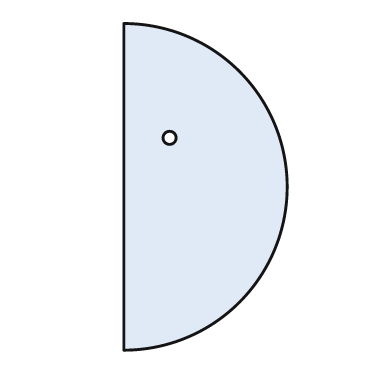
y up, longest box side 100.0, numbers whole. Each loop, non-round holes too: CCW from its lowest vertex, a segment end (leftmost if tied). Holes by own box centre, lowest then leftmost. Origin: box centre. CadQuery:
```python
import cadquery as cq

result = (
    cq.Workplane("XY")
    .moveTo(-25.0, -50.0)
    .threePointArc((25.0, 0.0), (-25.0, 50.0))
    .close()
    .moveTo(-11.0, 15.0)
    .circle(2.0)
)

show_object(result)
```